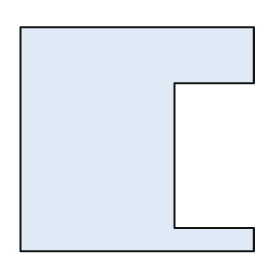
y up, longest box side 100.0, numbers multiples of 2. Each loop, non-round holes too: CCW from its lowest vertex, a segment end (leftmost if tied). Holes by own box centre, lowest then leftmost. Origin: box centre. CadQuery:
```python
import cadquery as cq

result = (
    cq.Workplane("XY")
    .moveTo(-50.0, -48.0)
    .lineTo(50.0, -48.0)
    .lineTo(50.0, -38.0)
    .lineTo(16.0, -38.0)
    .lineTo(16.0, 24.0)
    .lineTo(50.0, 24.0)
    .lineTo(50.0, 48.0)
    .lineTo(-50.0, 48.0)
    .close()
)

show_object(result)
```